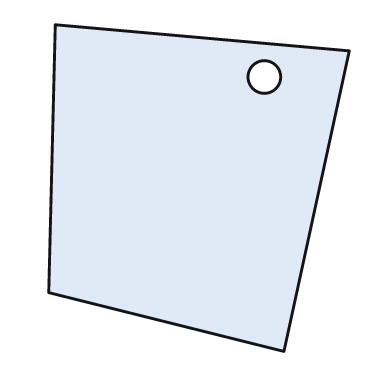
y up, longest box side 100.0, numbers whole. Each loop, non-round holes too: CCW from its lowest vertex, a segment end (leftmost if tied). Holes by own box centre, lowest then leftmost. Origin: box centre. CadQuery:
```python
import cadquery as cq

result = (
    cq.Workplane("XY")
    .moveTo(26.0, -50.0)
    .lineTo(46.0, 42.0)
    .lineTo(-44.0, 50.0)
    .lineTo(-46.0, -32.0)
    .close()
    .moveTo(20.0, 34.0)
    .circle(5.0)
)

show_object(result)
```